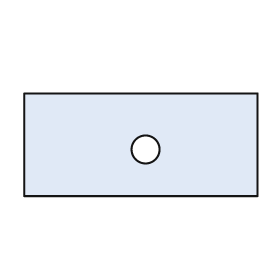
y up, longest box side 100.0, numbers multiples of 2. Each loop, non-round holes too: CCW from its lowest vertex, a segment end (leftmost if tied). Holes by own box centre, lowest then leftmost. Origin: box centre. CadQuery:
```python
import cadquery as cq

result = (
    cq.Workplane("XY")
    .moveTo(-50.0, -22.0)
    .lineTo(50.0, -22.0)
    .lineTo(50.0, 22.0)
    .lineTo(-50.0, 22.0)
    .close()
    .moveTo(2.0, -2.0)
    .circle(6.0)
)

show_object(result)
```